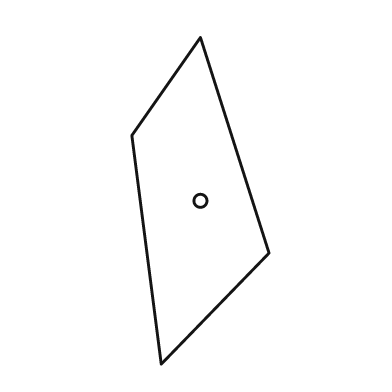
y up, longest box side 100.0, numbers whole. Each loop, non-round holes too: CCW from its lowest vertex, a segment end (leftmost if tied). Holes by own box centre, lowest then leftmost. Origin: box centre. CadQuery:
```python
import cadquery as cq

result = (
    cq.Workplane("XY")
    .moveTo(-12.0, -50.0)
    .lineTo(21.0, -16.0)
    .lineTo(0.0, 50.0)
    .lineTo(-21.0, 20.0)
    .close()
    .moveTo(0.0, 0.0)
    .circle(2.0)
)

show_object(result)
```